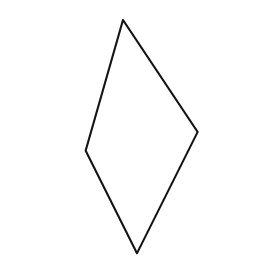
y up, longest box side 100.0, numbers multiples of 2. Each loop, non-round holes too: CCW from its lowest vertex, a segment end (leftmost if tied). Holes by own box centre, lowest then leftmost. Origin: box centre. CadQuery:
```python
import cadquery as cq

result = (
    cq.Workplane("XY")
    .moveTo(-2.0, -50.0)
    .lineTo(24.0, 2.0)
    .lineTo(-8.0, 50.0)
    .lineTo(-24.0, -6.0)
    .close()
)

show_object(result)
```